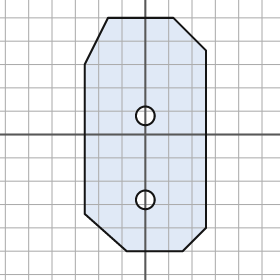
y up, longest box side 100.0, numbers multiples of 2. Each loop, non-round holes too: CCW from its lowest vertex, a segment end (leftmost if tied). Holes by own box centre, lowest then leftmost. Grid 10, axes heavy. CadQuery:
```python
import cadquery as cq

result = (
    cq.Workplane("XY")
    .moveTo(-8.0, -50.0)
    .lineTo(16.0, -50.0)
    .lineTo(26.0, -40.0)
    .lineTo(26.0, 36.0)
    .lineTo(12.0, 50.0)
    .lineTo(-16.0, 50.0)
    .lineTo(-26.0, 30.0)
    .lineTo(-26.0, -34.0)
    .close()
    .moveTo(0.0, -28.0)
    .circle(4.0)
    .moveTo(0.0, 8.0)
    .circle(4.0)
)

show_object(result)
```